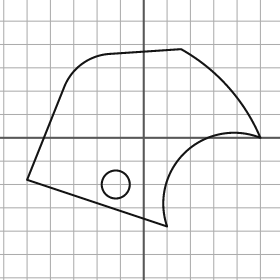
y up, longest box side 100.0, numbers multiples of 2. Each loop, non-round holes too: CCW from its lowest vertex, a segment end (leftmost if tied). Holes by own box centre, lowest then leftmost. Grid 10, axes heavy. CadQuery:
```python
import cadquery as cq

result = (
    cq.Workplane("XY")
    .moveTo(10.0, -38.0)
    .threePointArc((18.0, -6.0), (50.0, 0.0))
    .threePointArc((36.0, 22.0), (16.0, 38.0))
    .lineTo(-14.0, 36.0)
    .threePointArc((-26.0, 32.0), (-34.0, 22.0))
    .lineTo(-50.0, -18.0)
    .close()
    .moveTo(-12.0, -20.0)
    .circle(6.0)
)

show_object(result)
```